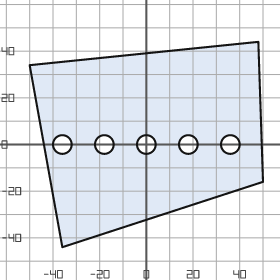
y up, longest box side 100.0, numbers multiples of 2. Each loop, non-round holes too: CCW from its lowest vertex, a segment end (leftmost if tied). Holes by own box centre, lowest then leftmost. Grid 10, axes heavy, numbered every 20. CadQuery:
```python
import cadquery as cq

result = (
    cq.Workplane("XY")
    .moveTo(-36.0, -44.0)
    .lineTo(50.0, -16.0)
    .lineTo(48.0, 44.0)
    .lineTo(-50.0, 34.0)
    .close()
    .moveTo(-36.0, 0.0)
    .circle(4.0)
    .moveTo(-18.0, 0.0)
    .circle(4.0)
    .moveTo(0.0, 0.0)
    .circle(4.0)
    .moveTo(18.0, 0.0)
    .circle(4.0)
    .moveTo(36.0, 0.0)
    .circle(4.0)
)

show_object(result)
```